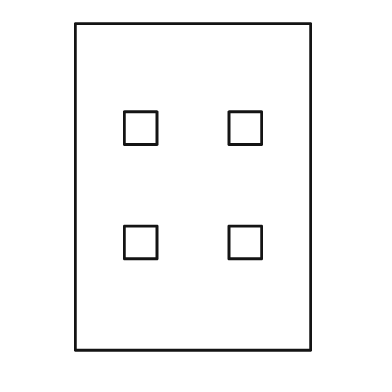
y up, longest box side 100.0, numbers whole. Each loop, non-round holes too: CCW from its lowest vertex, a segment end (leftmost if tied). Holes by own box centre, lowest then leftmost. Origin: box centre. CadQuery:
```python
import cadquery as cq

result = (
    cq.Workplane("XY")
    .moveTo(-36.0, -50.0)
    .lineTo(36.0, -50.0)
    .lineTo(36.0, 50.0)
    .lineTo(-36.0, 50.0)
    .close()
    .moveTo(-21.0, -22.0)
    .lineTo(-11.0, -22.0)
    .lineTo(-11.0, -12.0)
    .lineTo(-21.0, -12.0)
    .close()
    .moveTo(11.0, -22.0)
    .lineTo(21.0, -22.0)
    .lineTo(21.0, -12.0)
    .lineTo(11.0, -12.0)
    .close()
    .moveTo(-21.0, 13.0)
    .lineTo(-11.0, 13.0)
    .lineTo(-11.0, 23.0)
    .lineTo(-21.0, 23.0)
    .close()
    .moveTo(11.0, 13.0)
    .lineTo(21.0, 13.0)
    .lineTo(21.0, 23.0)
    .lineTo(11.0, 23.0)
    .close()
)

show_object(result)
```